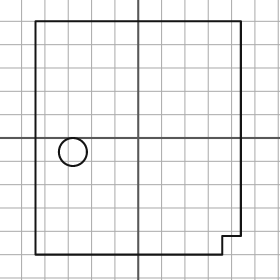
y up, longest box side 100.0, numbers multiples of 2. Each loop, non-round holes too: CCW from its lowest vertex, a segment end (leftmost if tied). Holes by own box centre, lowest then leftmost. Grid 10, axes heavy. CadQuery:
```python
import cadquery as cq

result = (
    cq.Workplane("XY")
    .moveTo(-44.0, -50.0)
    .lineTo(36.0, -50.0)
    .lineTo(36.0, -42.0)
    .lineTo(44.0, -42.0)
    .lineTo(44.0, 50.0)
    .lineTo(-44.0, 50.0)
    .close()
    .moveTo(-28.0, -6.0)
    .circle(6.0)
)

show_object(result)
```